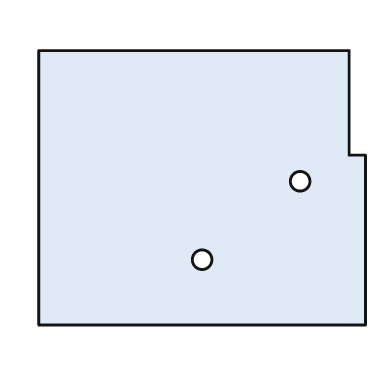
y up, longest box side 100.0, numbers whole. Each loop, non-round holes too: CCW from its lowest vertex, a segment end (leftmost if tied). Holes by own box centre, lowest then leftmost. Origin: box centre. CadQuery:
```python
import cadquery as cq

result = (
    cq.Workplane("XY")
    .moveTo(-50.0, -42.0)
    .lineTo(50.0, -42.0)
    .lineTo(50.0, 10.0)
    .lineTo(45.0, 10.0)
    .lineTo(45.0, 42.0)
    .lineTo(-50.0, 42.0)
    .close()
    .moveTo(0.0, -22.0)
    .circle(3.0)
    .moveTo(30.0, 2.0)
    .circle(3.0)
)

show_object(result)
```